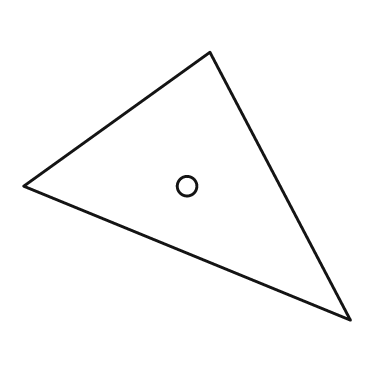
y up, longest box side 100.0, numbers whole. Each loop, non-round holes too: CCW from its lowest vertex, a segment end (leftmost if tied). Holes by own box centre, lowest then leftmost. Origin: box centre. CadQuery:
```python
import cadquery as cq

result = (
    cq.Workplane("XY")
    .moveTo(50.0, -41.0)
    .lineTo(7.0, 41.0)
    .lineTo(-50.0, 0.0)
    .close()
    .moveTo(0.0, 0.0)
    .circle(3.0)
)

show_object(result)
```